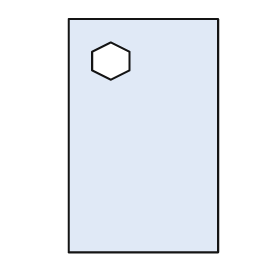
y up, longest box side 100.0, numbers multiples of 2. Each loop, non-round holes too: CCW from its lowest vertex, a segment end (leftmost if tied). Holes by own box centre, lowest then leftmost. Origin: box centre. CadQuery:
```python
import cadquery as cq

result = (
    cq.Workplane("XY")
    .moveTo(-32.0, -50.0)
    .lineTo(32.0, -50.0)
    .lineTo(32.0, 50.0)
    .lineTo(-32.0, 50.0)
    .close()
    .moveTo(-14.0, 24.0)
    .lineTo(-6.0, 28.0)
    .lineTo(-6.0, 36.0)
    .lineTo(-14.0, 40.0)
    .lineTo(-22.0, 36.0)
    .lineTo(-22.0, 28.0)
    .close()
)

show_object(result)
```